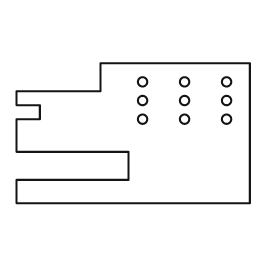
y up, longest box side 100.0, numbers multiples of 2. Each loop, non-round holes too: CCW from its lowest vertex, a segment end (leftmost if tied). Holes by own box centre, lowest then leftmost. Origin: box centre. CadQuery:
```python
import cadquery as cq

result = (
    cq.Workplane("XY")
    .moveTo(-50.0, -30.0)
    .lineTo(50.0, -30.0)
    .lineTo(50.0, 30.0)
    .lineTo(-14.0, 30.0)
    .lineTo(-14.0, 18.0)
    .lineTo(-50.0, 18.0)
    .lineTo(-50.0, 12.0)
    .lineTo(-40.0, 12.0)
    .lineTo(-40.0, 6.0)
    .lineTo(-50.0, 6.0)
    .lineTo(-50.0, -8.0)
    .lineTo(-2.0, -8.0)
    .lineTo(-2.0, -20.0)
    .lineTo(-50.0, -20.0)
    .close()
    .moveTo(4.0, 6.0)
    .circle(2.0)
    .moveTo(22.0, 6.0)
    .circle(2.0)
    .moveTo(40.0, 6.0)
    .circle(2.0)
    .moveTo(4.0, 14.0)
    .circle(2.0)
    .moveTo(22.0, 14.0)
    .circle(2.0)
    .moveTo(40.0, 14.0)
    .circle(2.0)
    .moveTo(4.0, 22.0)
    .circle(2.0)
    .moveTo(22.0, 22.0)
    .circle(2.0)
    .moveTo(40.0, 22.0)
    .circle(2.0)
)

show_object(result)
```